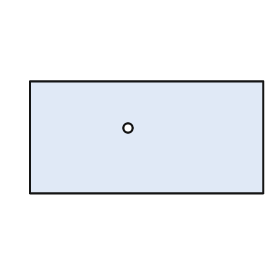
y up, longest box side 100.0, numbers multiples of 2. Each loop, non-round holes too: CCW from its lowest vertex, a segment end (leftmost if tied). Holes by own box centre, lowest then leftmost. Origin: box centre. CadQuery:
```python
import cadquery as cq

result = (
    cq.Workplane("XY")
    .moveTo(-50.0, -24.0)
    .lineTo(50.0, -24.0)
    .lineTo(50.0, 24.0)
    .lineTo(-50.0, 24.0)
    .close()
    .moveTo(-8.0, 4.0)
    .circle(2.0)
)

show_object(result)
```